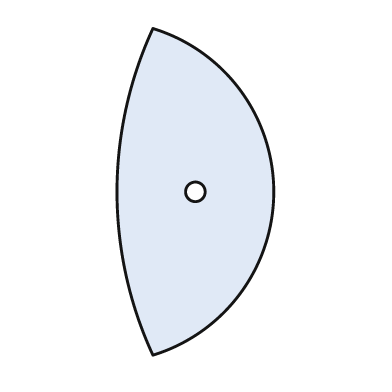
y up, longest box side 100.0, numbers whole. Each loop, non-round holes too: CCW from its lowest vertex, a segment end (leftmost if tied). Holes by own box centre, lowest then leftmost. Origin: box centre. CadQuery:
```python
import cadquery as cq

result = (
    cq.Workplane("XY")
    .moveTo(-13.0, -50.0)
    .threePointArc((24.0, 0.0), (-13.0, 50.0))
    .threePointArc((-24.0, 0.0), (-13.0, -50.0))
    .close()
    .moveTo(0.0, 0.0)
    .circle(3.0)
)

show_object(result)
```